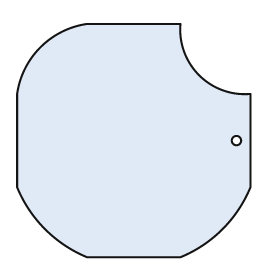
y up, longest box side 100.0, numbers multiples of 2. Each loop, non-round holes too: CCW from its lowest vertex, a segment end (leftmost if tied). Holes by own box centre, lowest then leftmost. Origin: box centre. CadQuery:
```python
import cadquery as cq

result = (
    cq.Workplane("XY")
    .moveTo(-20.0, -50.0)
    .lineTo(20.0, -50.0)
    .threePointArc((38.0, -38.0), (50.0, -20.0))
    .lineTo(50.0, 20.0)
    .threePointArc((28.0, 28.0), (20.0, 50.0))
    .lineTo(-20.0, 50.0)
    .threePointArc((-40.0, 40.0), (-50.0, 20.0))
    .lineTo(-50.0, -20.0)
    .threePointArc((-38.0, -38.0), (-20.0, -50.0))
    .close()
    .moveTo(44.0, 0.0)
    .circle(2.0)
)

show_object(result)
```